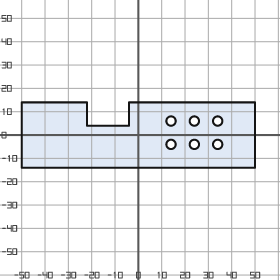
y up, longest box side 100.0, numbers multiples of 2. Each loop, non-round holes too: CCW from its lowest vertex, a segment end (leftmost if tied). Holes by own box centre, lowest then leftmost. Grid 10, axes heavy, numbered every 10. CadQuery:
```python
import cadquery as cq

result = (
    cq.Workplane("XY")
    .moveTo(-50.0, -14.0)
    .lineTo(50.0, -14.0)
    .lineTo(50.0, 14.0)
    .lineTo(-4.0, 14.0)
    .lineTo(-4.0, 4.0)
    .lineTo(-22.0, 4.0)
    .lineTo(-22.0, 14.0)
    .lineTo(-50.0, 14.0)
    .close()
    .moveTo(14.0, -4.0)
    .circle(2.0)
    .moveTo(24.0, -4.0)
    .circle(2.0)
    .moveTo(34.0, -4.0)
    .circle(2.0)
    .moveTo(14.0, 6.0)
    .circle(2.0)
    .moveTo(24.0, 6.0)
    .circle(2.0)
    .moveTo(34.0, 6.0)
    .circle(2.0)
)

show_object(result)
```